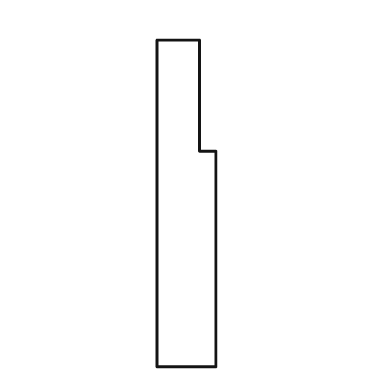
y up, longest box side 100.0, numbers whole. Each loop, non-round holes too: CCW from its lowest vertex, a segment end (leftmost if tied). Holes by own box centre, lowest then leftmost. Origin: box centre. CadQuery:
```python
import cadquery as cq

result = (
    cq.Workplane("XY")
    .moveTo(-9.0, -50.0)
    .lineTo(9.0, -50.0)
    .lineTo(9.0, 16.0)
    .lineTo(4.0, 16.0)
    .lineTo(4.0, 50.0)
    .lineTo(-9.0, 50.0)
    .close()
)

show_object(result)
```